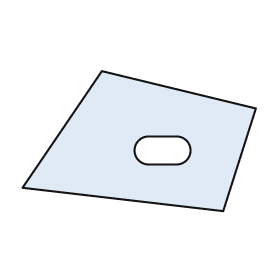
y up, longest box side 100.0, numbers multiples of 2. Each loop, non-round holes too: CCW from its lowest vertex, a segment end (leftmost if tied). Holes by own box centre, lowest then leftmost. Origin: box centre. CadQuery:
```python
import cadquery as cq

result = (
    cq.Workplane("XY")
    .moveTo(36.0, -30.0)
    .lineTo(50.0, 14.0)
    .lineTo(-16.0, 30.0)
    .lineTo(-50.0, -20.0)
    .close()
    .moveTo(4.0, -10.0)
    .lineTo(16.0, -10.0)
    .threePointArc((22.0, -4.0), (16.0, 2.0))
    .lineTo(4.0, 2.0)
    .threePointArc((-2.0, -4.0), (4.0, -10.0))
    .close()
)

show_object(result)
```